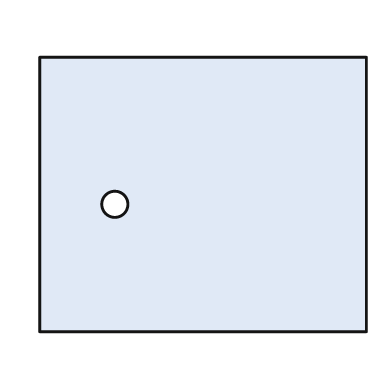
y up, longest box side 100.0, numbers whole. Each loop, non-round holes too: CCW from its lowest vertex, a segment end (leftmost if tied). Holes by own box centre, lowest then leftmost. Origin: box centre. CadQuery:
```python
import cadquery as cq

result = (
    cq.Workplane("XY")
    .moveTo(-50.0, -42.0)
    .lineTo(50.0, -42.0)
    .lineTo(50.0, 42.0)
    .lineTo(-50.0, 42.0)
    .close()
    .moveTo(-27.0, -3.0)
    .circle(4.0)
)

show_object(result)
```